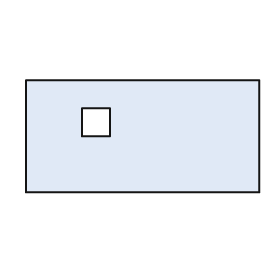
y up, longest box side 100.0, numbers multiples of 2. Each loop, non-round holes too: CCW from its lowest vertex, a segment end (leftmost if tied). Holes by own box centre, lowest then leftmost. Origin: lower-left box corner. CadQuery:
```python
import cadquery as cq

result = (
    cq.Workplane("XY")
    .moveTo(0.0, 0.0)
    .lineTo(100.0, 0.0)
    .lineTo(100.0, 48.0)
    .lineTo(0.0, 48.0)
    .close()
    .moveTo(24.0, 24.0)
    .lineTo(36.0, 24.0)
    .lineTo(36.0, 36.0)
    .lineTo(24.0, 36.0)
    .close()
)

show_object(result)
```